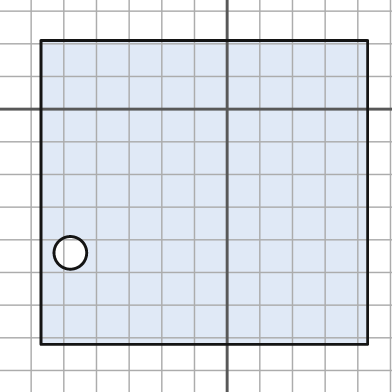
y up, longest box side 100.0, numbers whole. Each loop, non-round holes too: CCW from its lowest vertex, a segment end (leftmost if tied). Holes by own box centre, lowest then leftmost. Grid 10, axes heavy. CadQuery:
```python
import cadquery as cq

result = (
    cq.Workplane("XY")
    .moveTo(-57.0, -72.0)
    .lineTo(43.0, -72.0)
    .lineTo(43.0, 21.0)
    .lineTo(-57.0, 21.0)
    .close()
    .moveTo(-48.0, -44.0)
    .circle(5.0)
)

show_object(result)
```